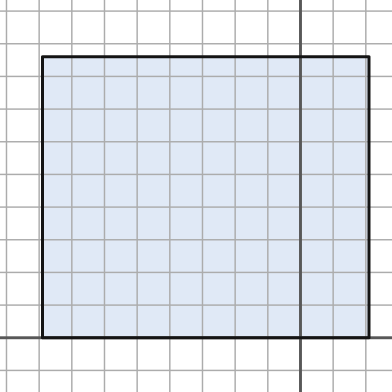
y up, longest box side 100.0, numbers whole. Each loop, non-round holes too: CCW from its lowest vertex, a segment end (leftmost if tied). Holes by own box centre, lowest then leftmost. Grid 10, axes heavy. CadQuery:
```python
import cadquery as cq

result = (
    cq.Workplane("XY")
    .moveTo(-79.0, 0.0)
    .lineTo(21.0, 0.0)
    .lineTo(21.0, 86.0)
    .lineTo(-79.0, 86.0)
    .close()
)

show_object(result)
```